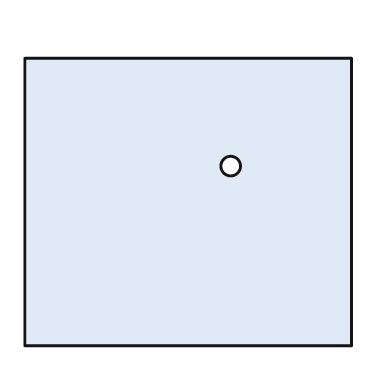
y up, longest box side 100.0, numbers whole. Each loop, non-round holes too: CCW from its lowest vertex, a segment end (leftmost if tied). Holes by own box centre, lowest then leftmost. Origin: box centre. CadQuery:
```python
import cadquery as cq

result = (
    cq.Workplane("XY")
    .moveTo(-50.0, -44.0)
    .lineTo(50.0, -44.0)
    .lineTo(50.0, 44.0)
    .lineTo(-50.0, 44.0)
    .close()
    .moveTo(13.0, 11.0)
    .circle(3.0)
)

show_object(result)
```